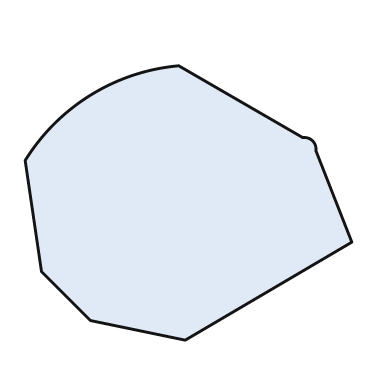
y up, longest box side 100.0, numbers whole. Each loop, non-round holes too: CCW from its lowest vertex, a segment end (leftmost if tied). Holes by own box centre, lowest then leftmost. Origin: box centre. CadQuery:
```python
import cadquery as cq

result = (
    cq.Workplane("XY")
    .moveTo(-1.0, -42.0)
    .lineTo(50.0, -12.0)
    .lineTo(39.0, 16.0)
    .threePointArc((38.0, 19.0), (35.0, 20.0))
    .lineTo(-3.0, 42.0)
    .threePointArc((-30.0, 33.0), (-50.0, 13.0))
    .lineTo(-45.0, -21.0)
    .lineTo(-30.0, -36.0)
    .close()
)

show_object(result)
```